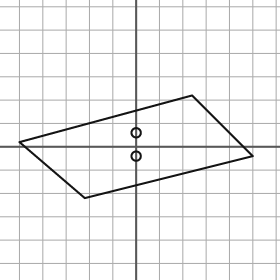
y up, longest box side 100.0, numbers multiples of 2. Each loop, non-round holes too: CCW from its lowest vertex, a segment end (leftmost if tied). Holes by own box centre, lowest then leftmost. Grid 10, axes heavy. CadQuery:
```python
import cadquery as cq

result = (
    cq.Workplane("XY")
    .moveTo(-22.0, -22.0)
    .lineTo(50.0, -4.0)
    .lineTo(24.0, 22.0)
    .lineTo(-50.0, 2.0)
    .close()
    .moveTo(0.0, -4.0)
    .circle(2.0)
    .moveTo(0.0, 6.0)
    .circle(2.0)
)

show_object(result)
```